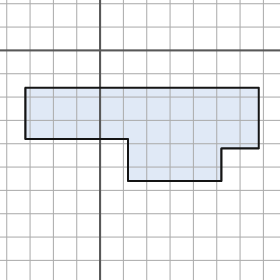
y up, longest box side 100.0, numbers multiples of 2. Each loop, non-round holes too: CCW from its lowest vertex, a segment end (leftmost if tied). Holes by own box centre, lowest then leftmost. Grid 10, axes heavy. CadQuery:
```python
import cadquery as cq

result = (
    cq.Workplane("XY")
    .moveTo(12.0, -56.0)
    .lineTo(52.0, -56.0)
    .lineTo(52.0, -42.0)
    .lineTo(68.0, -42.0)
    .lineTo(68.0, -16.0)
    .lineTo(-32.0, -16.0)
    .lineTo(-32.0, -38.0)
    .lineTo(12.0, -38.0)
    .close()
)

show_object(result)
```